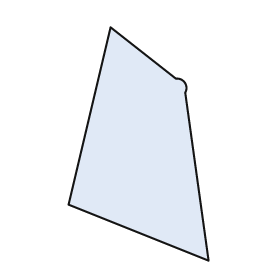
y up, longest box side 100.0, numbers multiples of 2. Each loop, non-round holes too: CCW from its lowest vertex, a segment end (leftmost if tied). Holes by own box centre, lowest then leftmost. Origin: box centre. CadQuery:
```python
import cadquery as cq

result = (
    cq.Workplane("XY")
    .moveTo(30.0, -50.0)
    .lineTo(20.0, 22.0)
    .threePointArc((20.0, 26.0), (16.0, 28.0))
    .lineTo(-12.0, 50.0)
    .lineTo(-30.0, -26.0)
    .close()
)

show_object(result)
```